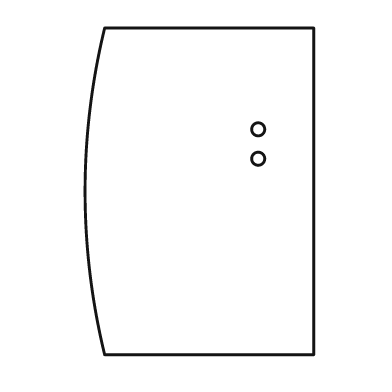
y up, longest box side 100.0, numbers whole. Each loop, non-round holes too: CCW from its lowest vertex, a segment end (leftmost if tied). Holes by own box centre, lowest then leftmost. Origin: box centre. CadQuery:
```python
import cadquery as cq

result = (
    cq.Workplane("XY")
    .moveTo(-29.0, -50.0)
    .lineTo(35.0, -50.0)
    .lineTo(35.0, 50.0)
    .lineTo(-29.0, 50.0)
    .threePointArc((-35.0, 0.0), (-29.0, -50.0))
    .close()
    .moveTo(18.0, 10.0)
    .circle(2.0)
    .moveTo(18.0, 19.0)
    .circle(2.0)
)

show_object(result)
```